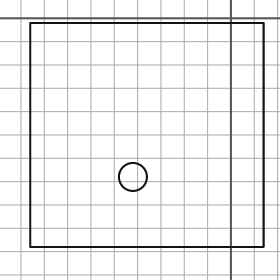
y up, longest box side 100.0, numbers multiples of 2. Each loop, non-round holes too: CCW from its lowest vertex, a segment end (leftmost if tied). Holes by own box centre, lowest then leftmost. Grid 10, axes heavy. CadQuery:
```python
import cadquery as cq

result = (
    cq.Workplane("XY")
    .moveTo(-86.0, -98.0)
    .lineTo(14.0, -98.0)
    .lineTo(14.0, -2.0)
    .lineTo(-86.0, -2.0)
    .close()
    .moveTo(-42.0, -68.0)
    .circle(6.0)
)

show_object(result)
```